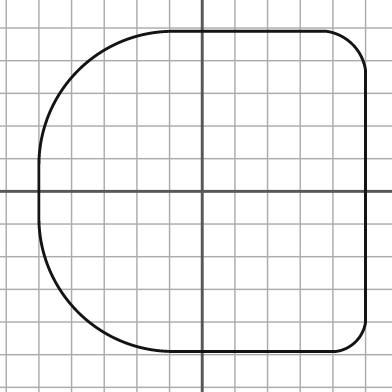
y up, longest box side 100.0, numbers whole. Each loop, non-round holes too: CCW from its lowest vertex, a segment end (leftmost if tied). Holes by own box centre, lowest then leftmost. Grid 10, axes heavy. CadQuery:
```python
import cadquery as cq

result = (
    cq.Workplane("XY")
    .moveTo(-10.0, -49.0)
    .lineTo(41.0, -49.0)
    .threePointArc((47.0, -46.0), (50.0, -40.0))
    .lineTo(50.0, 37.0)
    .threePointArc((46.0, 45.0), (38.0, 49.0))
    .lineTo(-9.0, 49.0)
    .threePointArc((-38.0, 37.0), (-50.0, 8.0))
    .lineTo(-50.0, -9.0)
    .threePointArc((-38.0, -37.0), (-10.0, -49.0))
    .close()
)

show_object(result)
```